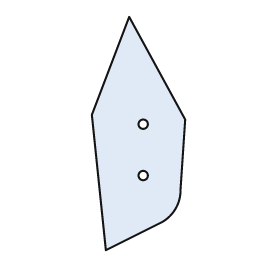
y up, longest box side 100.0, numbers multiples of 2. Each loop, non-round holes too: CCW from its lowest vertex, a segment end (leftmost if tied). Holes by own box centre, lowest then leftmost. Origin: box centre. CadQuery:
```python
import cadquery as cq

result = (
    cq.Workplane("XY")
    .moveTo(-14.0, -50.0)
    .lineTo(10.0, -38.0)
    .threePointArc((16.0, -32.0), (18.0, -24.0))
    .lineTo(20.0, 6.0)
    .lineTo(-4.0, 50.0)
    .lineTo(-20.0, 8.0)
    .close()
    .moveTo(2.0, -18.0)
    .circle(2.0)
    .moveTo(2.0, 4.0)
    .circle(2.0)
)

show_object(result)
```